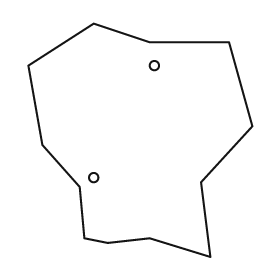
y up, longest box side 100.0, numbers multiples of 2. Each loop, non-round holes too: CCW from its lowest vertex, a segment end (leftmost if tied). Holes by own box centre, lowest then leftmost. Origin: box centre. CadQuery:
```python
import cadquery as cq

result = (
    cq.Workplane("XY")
    .moveTo(30.0, -50.0)
    .lineTo(26.0, -18.0)
    .lineTo(48.0, 6.0)
    .lineTo(38.0, 42.0)
    .lineTo(4.0, 42.0)
    .lineTo(-20.0, 50.0)
    .lineTo(-48.0, 32.0)
    .lineTo(-42.0, -2.0)
    .lineTo(-26.0, -20.0)
    .lineTo(-24.0, -42.0)
    .lineTo(-14.0, -44.0)
    .lineTo(4.0, -42.0)
    .close()
    .moveTo(-20.0, -16.0)
    .circle(2.0)
    .moveTo(6.0, 32.0)
    .circle(2.0)
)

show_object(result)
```